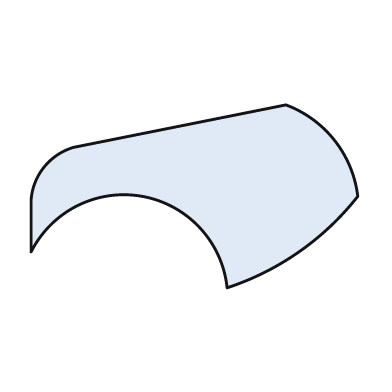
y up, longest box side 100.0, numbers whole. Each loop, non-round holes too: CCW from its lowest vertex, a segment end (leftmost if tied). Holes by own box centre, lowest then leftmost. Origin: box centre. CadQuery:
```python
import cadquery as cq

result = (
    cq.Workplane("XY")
    .moveTo(10.0, -28.0)
    .threePointArc((32.0, -17.0), (50.0, 0.0))
    .threePointArc((43.0, 17.0), (28.0, 28.0))
    .lineTo(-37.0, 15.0)
    .threePointArc((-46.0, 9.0), (-50.0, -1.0))
    .lineTo(-50.0, -17.0)
    .threePointArc((-16.0, 0.0), (10.0, -28.0))
    .close()
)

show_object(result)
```